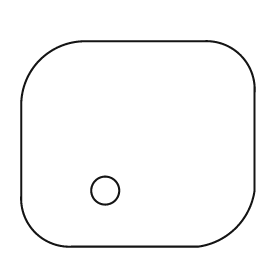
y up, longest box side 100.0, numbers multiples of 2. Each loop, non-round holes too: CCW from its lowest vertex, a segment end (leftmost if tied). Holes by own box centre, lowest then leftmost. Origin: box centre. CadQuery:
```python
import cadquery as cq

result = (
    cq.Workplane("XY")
    .moveTo(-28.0, -44.0)
    .lineTo(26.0, -44.0)
    .threePointArc((42.0, -36.0), (50.0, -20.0))
    .lineTo(50.0, 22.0)
    .threePointArc((44.0, 38.0), (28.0, 44.0))
    .lineTo(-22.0, 44.0)
    .threePointArc((-42.0, 36.0), (-50.0, 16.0))
    .lineTo(-50.0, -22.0)
    .threePointArc((-44.0, -38.0), (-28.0, -44.0))
    .close()
    .moveTo(-14.0, -20.0)
    .circle(6.0)
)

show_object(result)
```